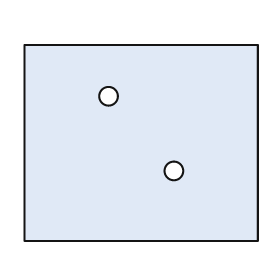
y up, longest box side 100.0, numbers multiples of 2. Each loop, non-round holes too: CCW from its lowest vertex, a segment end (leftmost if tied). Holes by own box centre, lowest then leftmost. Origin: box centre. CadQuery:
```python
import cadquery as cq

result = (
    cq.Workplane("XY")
    .moveTo(-50.0, -42.0)
    .lineTo(50.0, -42.0)
    .lineTo(50.0, 42.0)
    .lineTo(-50.0, 42.0)
    .close()
    .moveTo(14.0, -12.0)
    .circle(4.0)
    .moveTo(-14.0, 20.0)
    .circle(4.0)
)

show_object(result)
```